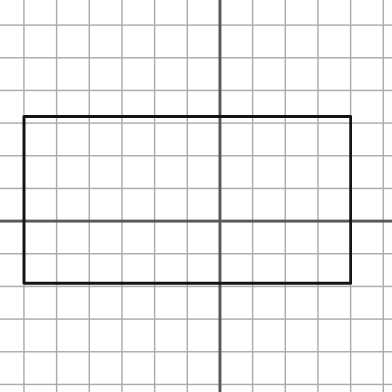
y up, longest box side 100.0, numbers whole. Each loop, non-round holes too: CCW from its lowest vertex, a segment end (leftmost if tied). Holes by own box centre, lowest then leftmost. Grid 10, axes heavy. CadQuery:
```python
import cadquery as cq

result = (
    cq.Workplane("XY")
    .moveTo(-60.0, -19.0)
    .lineTo(40.0, -19.0)
    .lineTo(40.0, 32.0)
    .lineTo(-60.0, 32.0)
    .close()
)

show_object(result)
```